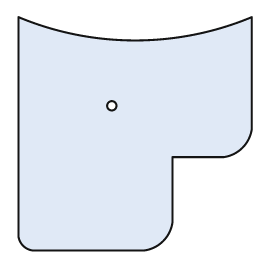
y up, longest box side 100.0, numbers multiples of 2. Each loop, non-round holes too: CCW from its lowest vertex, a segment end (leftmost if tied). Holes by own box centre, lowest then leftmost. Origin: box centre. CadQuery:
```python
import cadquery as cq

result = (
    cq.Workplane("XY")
    .moveTo(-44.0, -50.0)
    .lineTo(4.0, -50.0)
    .threePointArc((12.0, -46.0), (16.0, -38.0))
    .lineTo(16.0, -10.0)
    .lineTo(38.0, -10.0)
    .threePointArc((46.0, -6.0), (50.0, 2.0))
    .lineTo(50.0, 50.0)
    .threePointArc((0.0, 40.0), (-50.0, 50.0))
    .lineTo(-50.0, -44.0)
    .threePointArc((-48.0, -48.0), (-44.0, -50.0))
    .close()
    .moveTo(-10.0, 12.0)
    .circle(2.0)
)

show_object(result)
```